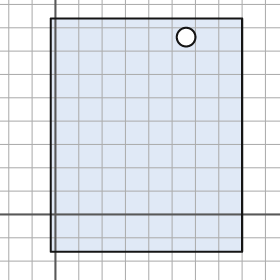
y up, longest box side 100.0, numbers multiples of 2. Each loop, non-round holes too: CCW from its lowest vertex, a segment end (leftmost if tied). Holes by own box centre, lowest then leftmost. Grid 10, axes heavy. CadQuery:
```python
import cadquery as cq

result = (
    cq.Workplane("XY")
    .moveTo(-2.0, -16.0)
    .lineTo(80.0, -16.0)
    .lineTo(80.0, 84.0)
    .lineTo(-2.0, 84.0)
    .close()
    .moveTo(56.0, 76.0)
    .circle(4.0)
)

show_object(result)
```